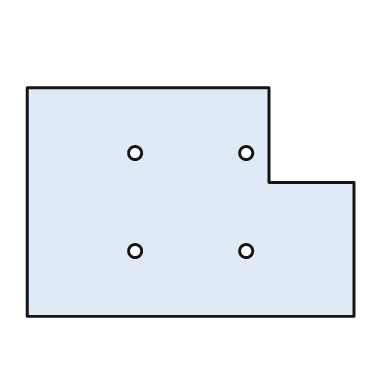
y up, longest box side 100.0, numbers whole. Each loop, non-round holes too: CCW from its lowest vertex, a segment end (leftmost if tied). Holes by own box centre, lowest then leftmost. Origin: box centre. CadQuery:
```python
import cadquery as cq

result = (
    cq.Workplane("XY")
    .moveTo(-50.0, -35.0)
    .lineTo(50.0, -35.0)
    .lineTo(50.0, 6.0)
    .lineTo(24.0, 6.0)
    .lineTo(24.0, 35.0)
    .lineTo(-50.0, 35.0)
    .close()
    .moveTo(-17.0, -15.0)
    .circle(2.0)
    .moveTo(17.0, -15.0)
    .circle(2.0)
    .moveTo(-17.0, 15.0)
    .circle(2.0)
    .moveTo(17.0, 15.0)
    .circle(2.0)
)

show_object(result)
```